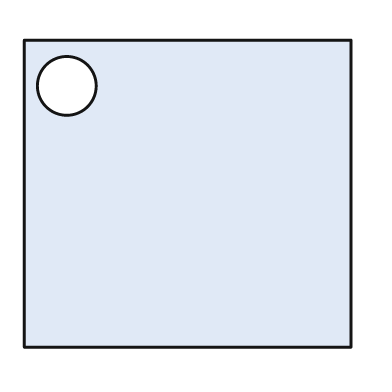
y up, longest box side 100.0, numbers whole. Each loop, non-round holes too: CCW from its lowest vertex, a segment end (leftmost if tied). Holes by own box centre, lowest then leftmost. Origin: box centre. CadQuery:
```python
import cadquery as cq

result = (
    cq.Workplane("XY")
    .moveTo(-50.0, -47.0)
    .lineTo(50.0, -47.0)
    .lineTo(50.0, 47.0)
    .lineTo(-50.0, 47.0)
    .close()
    .moveTo(-37.0, 33.0)
    .circle(9.0)
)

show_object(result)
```